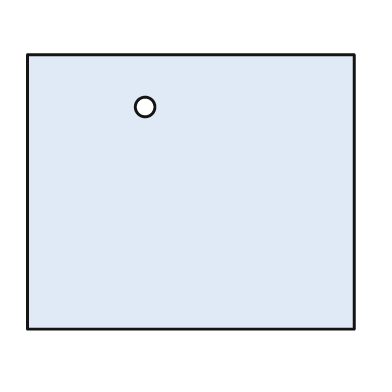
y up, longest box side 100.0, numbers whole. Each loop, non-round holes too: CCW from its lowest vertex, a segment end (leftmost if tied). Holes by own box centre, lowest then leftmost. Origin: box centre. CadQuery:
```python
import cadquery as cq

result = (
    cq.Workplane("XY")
    .moveTo(-50.0, -42.0)
    .lineTo(50.0, -42.0)
    .lineTo(50.0, 42.0)
    .lineTo(-50.0, 42.0)
    .close()
    .moveTo(-14.0, 26.0)
    .circle(3.0)
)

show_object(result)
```